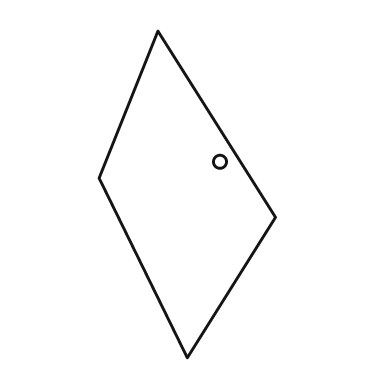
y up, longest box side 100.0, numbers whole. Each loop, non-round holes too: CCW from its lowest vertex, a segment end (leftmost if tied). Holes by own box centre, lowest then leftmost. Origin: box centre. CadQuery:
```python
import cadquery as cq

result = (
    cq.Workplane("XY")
    .moveTo(0.0, -50.0)
    .lineTo(27.0, -7.0)
    .lineTo(-9.0, 50.0)
    .lineTo(-27.0, 5.0)
    .close()
    .moveTo(10.0, 10.0)
    .circle(2.0)
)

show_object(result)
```